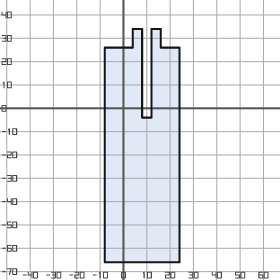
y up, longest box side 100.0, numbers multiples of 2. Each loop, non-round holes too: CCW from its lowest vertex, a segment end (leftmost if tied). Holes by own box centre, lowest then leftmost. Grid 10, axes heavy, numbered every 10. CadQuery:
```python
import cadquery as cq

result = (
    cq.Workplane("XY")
    .moveTo(-8.0, -66.0)
    .lineTo(24.0, -66.0)
    .lineTo(24.0, 26.0)
    .lineTo(16.0, 26.0)
    .lineTo(16.0, 34.0)
    .lineTo(12.0, 34.0)
    .lineTo(12.0, -4.0)
    .lineTo(8.0, -4.0)
    .lineTo(8.0, 34.0)
    .lineTo(4.0, 34.0)
    .lineTo(4.0, 26.0)
    .lineTo(-8.0, 26.0)
    .close()
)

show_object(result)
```